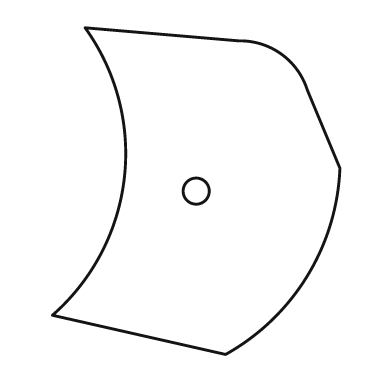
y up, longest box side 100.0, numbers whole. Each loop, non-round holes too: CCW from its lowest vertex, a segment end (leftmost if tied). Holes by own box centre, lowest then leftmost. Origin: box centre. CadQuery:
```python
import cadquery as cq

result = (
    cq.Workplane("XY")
    .moveTo(9.0, -50.0)
    .threePointArc((34.0, -26.0), (44.0, 7.0))
    .lineTo(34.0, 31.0)
    .threePointArc((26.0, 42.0), (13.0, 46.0))
    .lineTo(-34.0, 50.0)
    .threePointArc((-22.0, 4.0), (-44.0, -38.0))
    .close()
    .moveTo(0.0, 0.0)
    .circle(4.0)
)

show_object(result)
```